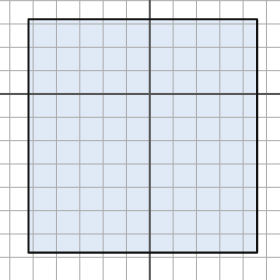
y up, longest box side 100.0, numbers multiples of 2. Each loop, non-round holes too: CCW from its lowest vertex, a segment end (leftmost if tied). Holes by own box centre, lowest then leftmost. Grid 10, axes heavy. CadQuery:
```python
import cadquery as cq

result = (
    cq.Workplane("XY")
    .moveTo(-52.0, -68.0)
    .lineTo(46.0, -68.0)
    .lineTo(46.0, 32.0)
    .lineTo(-52.0, 32.0)
    .close()
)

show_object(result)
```